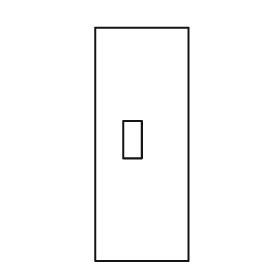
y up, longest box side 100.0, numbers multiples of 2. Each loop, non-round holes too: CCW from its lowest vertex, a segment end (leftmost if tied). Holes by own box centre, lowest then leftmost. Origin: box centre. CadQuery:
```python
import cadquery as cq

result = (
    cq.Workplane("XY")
    .moveTo(-20.0, -50.0)
    .lineTo(20.0, -50.0)
    .lineTo(20.0, 50.0)
    .lineTo(-20.0, 50.0)
    .close()
    .moveTo(-8.0, -6.0)
    .lineTo(0.0, -6.0)
    .lineTo(0.0, 10.0)
    .lineTo(-8.0, 10.0)
    .close()
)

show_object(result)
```